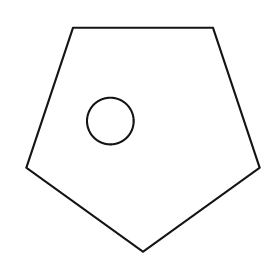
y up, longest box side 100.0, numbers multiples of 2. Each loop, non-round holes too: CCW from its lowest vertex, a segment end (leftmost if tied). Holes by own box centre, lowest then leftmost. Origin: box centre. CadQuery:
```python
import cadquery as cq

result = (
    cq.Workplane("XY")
    .moveTo(0.0, -48.0)
    .lineTo(50.0, -12.0)
    .lineTo(30.0, 48.0)
    .lineTo(-30.0, 48.0)
    .lineTo(-50.0, -12.0)
    .close()
    .moveTo(-14.0, 8.0)
    .circle(10.0)
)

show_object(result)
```